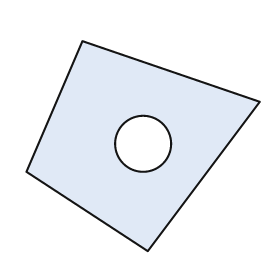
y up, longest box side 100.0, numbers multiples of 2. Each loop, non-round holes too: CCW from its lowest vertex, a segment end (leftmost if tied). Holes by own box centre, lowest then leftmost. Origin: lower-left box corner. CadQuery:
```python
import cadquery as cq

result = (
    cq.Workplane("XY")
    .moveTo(52.0, 0.0)
    .lineTo(100.0, 64.0)
    .lineTo(24.0, 90.0)
    .lineTo(0.0, 34.0)
    .close()
    .moveTo(50.0, 46.0)
    .circle(12.0)
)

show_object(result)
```